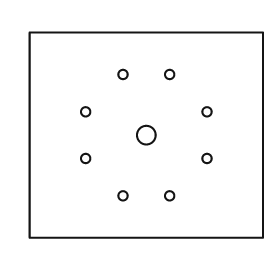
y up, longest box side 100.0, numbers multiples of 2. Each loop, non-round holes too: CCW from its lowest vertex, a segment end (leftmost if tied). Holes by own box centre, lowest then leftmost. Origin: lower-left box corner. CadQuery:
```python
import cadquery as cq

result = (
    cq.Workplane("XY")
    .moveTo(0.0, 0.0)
    .lineTo(100.0, 0.0)
    .lineTo(100.0, 88.0)
    .lineTo(0.0, 88.0)
    .close()
    .moveTo(40.0, 18.0)
    .circle(2.0)
    .moveTo(60.0, 18.0)
    .circle(2.0)
    .moveTo(24.0, 34.0)
    .circle(2.0)
    .moveTo(76.0, 34.0)
    .circle(2.0)
    .moveTo(50.0, 44.0)
    .circle(4.0)
    .moveTo(24.0, 54.0)
    .circle(2.0)
    .moveTo(76.0, 54.0)
    .circle(2.0)
    .moveTo(40.0, 70.0)
    .circle(2.0)
    .moveTo(60.0, 70.0)
    .circle(2.0)
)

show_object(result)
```